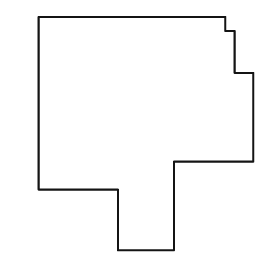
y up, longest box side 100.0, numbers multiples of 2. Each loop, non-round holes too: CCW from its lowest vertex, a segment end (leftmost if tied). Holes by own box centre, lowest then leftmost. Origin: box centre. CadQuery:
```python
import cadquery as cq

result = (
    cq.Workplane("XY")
    .moveTo(-12.0, -50.0)
    .lineTo(12.0, -50.0)
    .lineTo(12.0, -12.0)
    .lineTo(46.0, -12.0)
    .lineTo(46.0, 26.0)
    .lineTo(38.0, 26.0)
    .lineTo(38.0, 44.0)
    .lineTo(34.0, 44.0)
    .lineTo(34.0, 50.0)
    .lineTo(-46.0, 50.0)
    .lineTo(-46.0, -24.0)
    .lineTo(-12.0, -24.0)
    .close()
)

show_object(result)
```